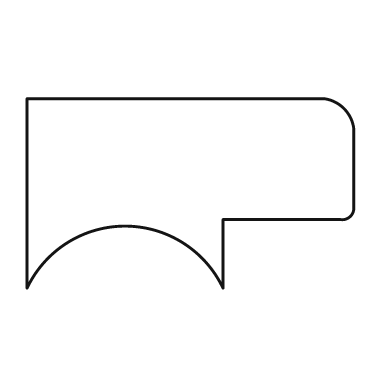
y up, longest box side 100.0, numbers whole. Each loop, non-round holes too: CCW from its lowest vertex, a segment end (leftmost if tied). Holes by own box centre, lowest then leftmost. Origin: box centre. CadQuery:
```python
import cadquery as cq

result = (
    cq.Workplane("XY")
    .moveTo(-50.0, -29.0)
    .threePointArc((-20.0, -10.0), (10.0, -29.0))
    .lineTo(10.0, -8.0)
    .lineTo(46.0, -8.0)
    .threePointArc((49.0, -7.0), (50.0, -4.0))
    .lineTo(50.0, 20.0)
    .threePointArc((47.0, 26.0), (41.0, 29.0))
    .lineTo(-50.0, 29.0)
    .close()
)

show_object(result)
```